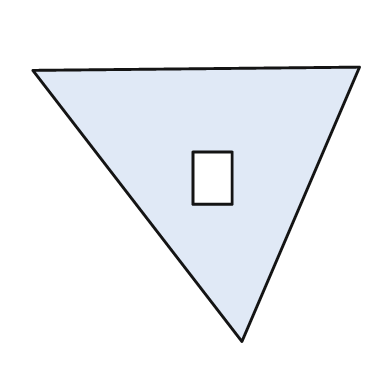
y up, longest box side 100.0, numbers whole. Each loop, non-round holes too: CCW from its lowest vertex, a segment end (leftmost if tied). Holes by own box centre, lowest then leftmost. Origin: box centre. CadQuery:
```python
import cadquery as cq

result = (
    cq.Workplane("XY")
    .moveTo(14.0, -42.0)
    .lineTo(50.0, 42.0)
    .lineTo(-50.0, 41.0)
    .close()
    .moveTo(-1.0, 0.0)
    .lineTo(11.0, 0.0)
    .lineTo(11.0, 16.0)
    .lineTo(-1.0, 16.0)
    .close()
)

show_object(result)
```